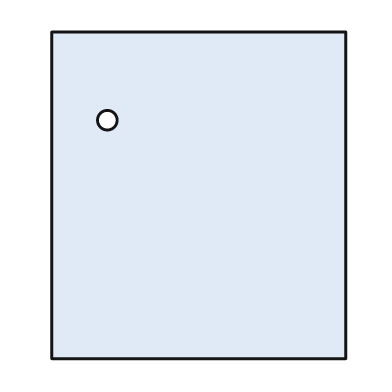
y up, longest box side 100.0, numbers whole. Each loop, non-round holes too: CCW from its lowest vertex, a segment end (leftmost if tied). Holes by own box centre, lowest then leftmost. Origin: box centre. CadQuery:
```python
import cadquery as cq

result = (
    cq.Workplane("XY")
    .moveTo(-45.0, -50.0)
    .lineTo(45.0, -50.0)
    .lineTo(45.0, 50.0)
    .lineTo(-45.0, 50.0)
    .close()
    .moveTo(-28.0, 23.0)
    .circle(3.0)
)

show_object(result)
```